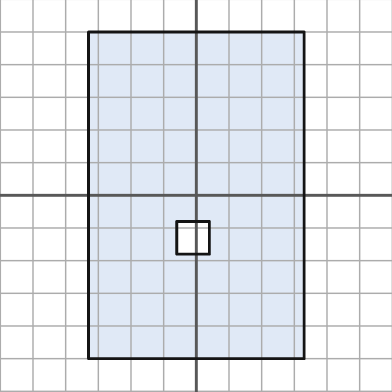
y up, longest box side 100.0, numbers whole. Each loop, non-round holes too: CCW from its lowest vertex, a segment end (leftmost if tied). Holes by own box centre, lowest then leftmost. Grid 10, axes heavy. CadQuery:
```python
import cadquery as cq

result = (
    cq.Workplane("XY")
    .moveTo(-33.0, -50.0)
    .lineTo(33.0, -50.0)
    .lineTo(33.0, 50.0)
    .lineTo(-33.0, 50.0)
    .close()
    .moveTo(-6.0, -18.0)
    .lineTo(4.0, -18.0)
    .lineTo(4.0, -8.0)
    .lineTo(-6.0, -8.0)
    .close()
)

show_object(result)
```